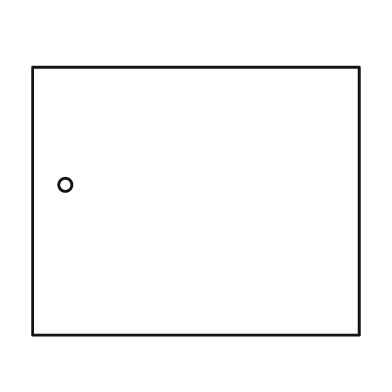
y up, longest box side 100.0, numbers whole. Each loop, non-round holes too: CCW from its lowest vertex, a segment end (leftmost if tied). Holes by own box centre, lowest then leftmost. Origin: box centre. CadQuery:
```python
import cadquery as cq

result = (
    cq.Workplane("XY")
    .moveTo(-50.0, -41.0)
    .lineTo(50.0, -41.0)
    .lineTo(50.0, 41.0)
    .lineTo(-50.0, 41.0)
    .close()
    .moveTo(-40.0, 5.0)
    .circle(2.0)
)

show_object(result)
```